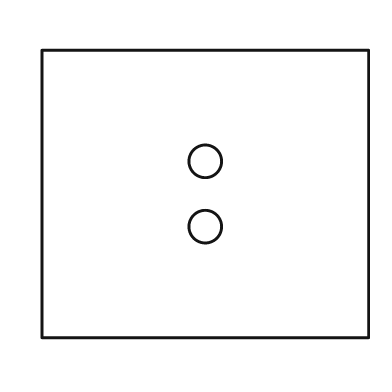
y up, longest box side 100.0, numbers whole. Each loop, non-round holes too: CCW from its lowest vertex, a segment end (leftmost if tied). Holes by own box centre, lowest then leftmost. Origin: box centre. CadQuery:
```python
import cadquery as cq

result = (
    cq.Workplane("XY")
    .moveTo(-50.0, -44.0)
    .lineTo(50.0, -44.0)
    .lineTo(50.0, 44.0)
    .lineTo(-50.0, 44.0)
    .close()
    .moveTo(0.0, -10.0)
    .circle(5.0)
    .moveTo(0.0, 10.0)
    .circle(5.0)
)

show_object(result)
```